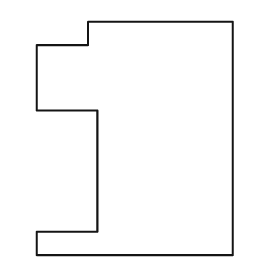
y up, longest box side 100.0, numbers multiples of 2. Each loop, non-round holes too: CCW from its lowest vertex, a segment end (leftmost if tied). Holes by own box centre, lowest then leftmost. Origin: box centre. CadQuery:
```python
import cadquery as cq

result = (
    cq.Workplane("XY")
    .moveTo(-42.0, -50.0)
    .lineTo(42.0, -50.0)
    .lineTo(42.0, 50.0)
    .lineTo(-20.0, 50.0)
    .lineTo(-20.0, 40.0)
    .lineTo(-42.0, 40.0)
    .lineTo(-42.0, 12.0)
    .lineTo(-16.0, 12.0)
    .lineTo(-16.0, -40.0)
    .lineTo(-42.0, -40.0)
    .close()
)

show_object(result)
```